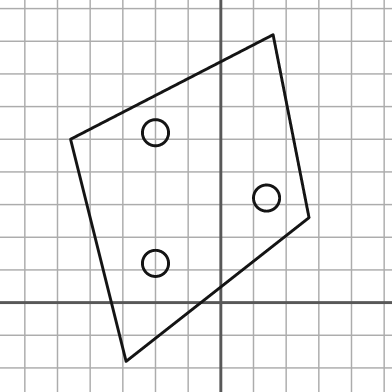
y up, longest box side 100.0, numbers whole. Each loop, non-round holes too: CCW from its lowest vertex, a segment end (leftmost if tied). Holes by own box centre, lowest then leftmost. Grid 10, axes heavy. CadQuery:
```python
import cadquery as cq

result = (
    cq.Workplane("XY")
    .moveTo(-29.0, -18.0)
    .lineTo(27.0, 26.0)
    .lineTo(16.0, 82.0)
    .lineTo(-46.0, 50.0)
    .close()
    .moveTo(-20.0, 12.0)
    .circle(4.0)
    .moveTo(14.0, 32.0)
    .circle(4.0)
    .moveTo(-20.0, 52.0)
    .circle(4.0)
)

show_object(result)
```